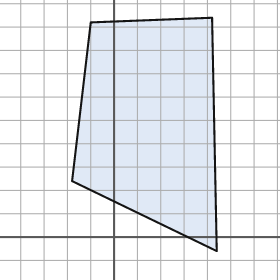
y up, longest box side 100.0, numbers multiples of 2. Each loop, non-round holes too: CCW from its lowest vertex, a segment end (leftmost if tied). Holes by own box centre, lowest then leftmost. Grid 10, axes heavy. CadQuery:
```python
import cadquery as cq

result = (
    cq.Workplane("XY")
    .moveTo(44.0, -6.0)
    .lineTo(42.0, 94.0)
    .lineTo(-10.0, 92.0)
    .lineTo(-18.0, 24.0)
    .close()
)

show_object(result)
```